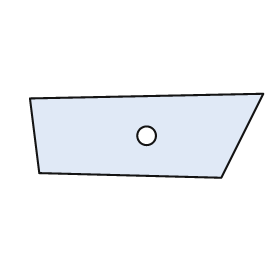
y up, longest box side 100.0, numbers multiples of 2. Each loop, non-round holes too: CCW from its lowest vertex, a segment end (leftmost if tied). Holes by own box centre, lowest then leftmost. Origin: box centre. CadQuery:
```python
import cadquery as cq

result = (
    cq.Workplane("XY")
    .moveTo(32.0, -18.0)
    .lineTo(50.0, 18.0)
    .lineTo(-50.0, 16.0)
    .lineTo(-46.0, -16.0)
    .close()
    .moveTo(0.0, 0.0)
    .circle(4.0)
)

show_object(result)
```